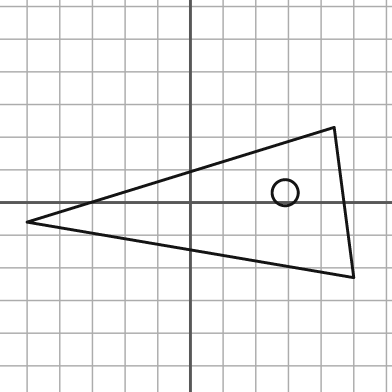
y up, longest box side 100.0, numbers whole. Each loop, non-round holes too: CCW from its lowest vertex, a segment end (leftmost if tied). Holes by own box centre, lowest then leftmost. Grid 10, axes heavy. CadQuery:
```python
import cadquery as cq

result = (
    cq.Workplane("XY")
    .moveTo(50.0, -23.0)
    .lineTo(44.0, 23.0)
    .lineTo(-50.0, -6.0)
    .close()
    .moveTo(29.0, 3.0)
    .circle(4.0)
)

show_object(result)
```